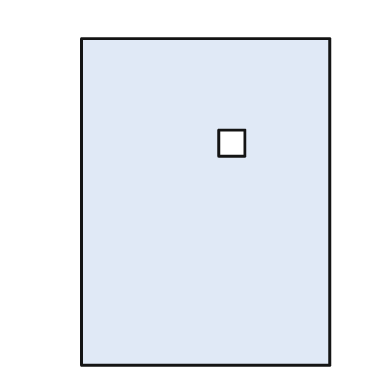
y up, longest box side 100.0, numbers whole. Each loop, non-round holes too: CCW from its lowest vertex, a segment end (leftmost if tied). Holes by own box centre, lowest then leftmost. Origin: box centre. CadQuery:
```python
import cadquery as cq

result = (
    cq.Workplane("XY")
    .moveTo(-38.0, -50.0)
    .lineTo(38.0, -50.0)
    .lineTo(38.0, 50.0)
    .lineTo(-38.0, 50.0)
    .close()
    .moveTo(4.0, 14.0)
    .lineTo(12.0, 14.0)
    .lineTo(12.0, 22.0)
    .lineTo(4.0, 22.0)
    .close()
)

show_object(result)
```